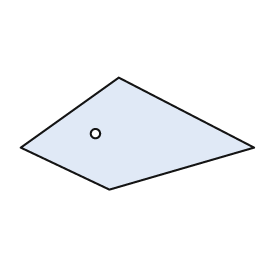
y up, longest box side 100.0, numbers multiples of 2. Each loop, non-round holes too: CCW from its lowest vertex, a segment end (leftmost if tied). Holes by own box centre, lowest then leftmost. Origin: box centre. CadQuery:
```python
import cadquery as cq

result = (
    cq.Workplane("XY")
    .moveTo(-12.0, -24.0)
    .lineTo(50.0, -6.0)
    .lineTo(-8.0, 24.0)
    .lineTo(-50.0, -6.0)
    .close()
    .moveTo(-18.0, 0.0)
    .circle(2.0)
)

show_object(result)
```